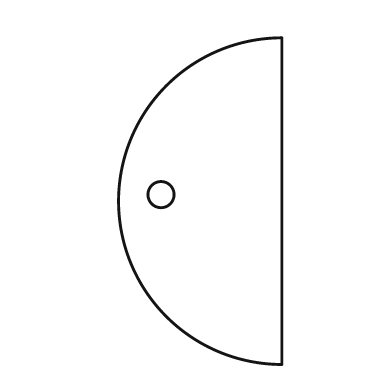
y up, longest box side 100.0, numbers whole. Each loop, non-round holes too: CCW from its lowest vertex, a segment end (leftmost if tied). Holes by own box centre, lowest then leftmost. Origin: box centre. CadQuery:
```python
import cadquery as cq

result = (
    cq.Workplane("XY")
    .moveTo(25.0, -50.0)
    .lineTo(25.0, 50.0)
    .threePointArc((-25.0, 0.0), (25.0, -50.0))
    .close()
    .moveTo(-12.0, 2.0)
    .circle(4.0)
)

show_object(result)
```